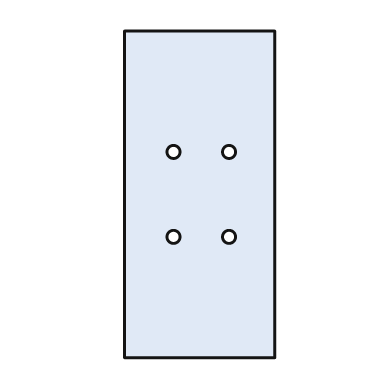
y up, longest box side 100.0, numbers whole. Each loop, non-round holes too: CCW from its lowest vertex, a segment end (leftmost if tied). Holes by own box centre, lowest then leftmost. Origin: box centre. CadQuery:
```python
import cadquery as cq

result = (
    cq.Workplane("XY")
    .moveTo(-23.0, -50.0)
    .lineTo(23.0, -50.0)
    .lineTo(23.0, 50.0)
    .lineTo(-23.0, 50.0)
    .close()
    .moveTo(-8.0, -13.0)
    .circle(2.0)
    .moveTo(9.0, -13.0)
    .circle(2.0)
    .moveTo(-8.0, 13.0)
    .circle(2.0)
    .moveTo(9.0, 13.0)
    .circle(2.0)
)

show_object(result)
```